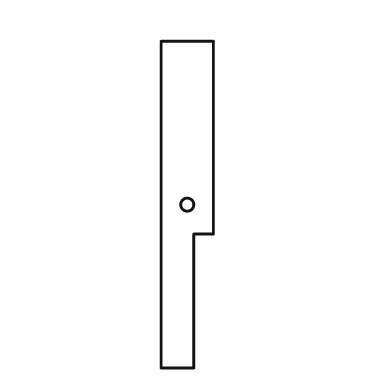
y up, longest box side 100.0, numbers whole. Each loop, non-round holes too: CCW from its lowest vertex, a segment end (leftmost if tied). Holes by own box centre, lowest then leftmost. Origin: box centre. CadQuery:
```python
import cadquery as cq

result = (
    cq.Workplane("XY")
    .moveTo(-8.0, -50.0)
    .lineTo(2.0, -50.0)
    .lineTo(2.0, -9.0)
    .lineTo(8.0, -9.0)
    .lineTo(8.0, 50.0)
    .lineTo(-8.0, 50.0)
    .close()
    .moveTo(0.0, 0.0)
    .circle(2.0)
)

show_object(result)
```